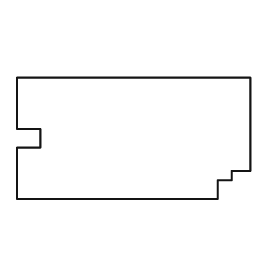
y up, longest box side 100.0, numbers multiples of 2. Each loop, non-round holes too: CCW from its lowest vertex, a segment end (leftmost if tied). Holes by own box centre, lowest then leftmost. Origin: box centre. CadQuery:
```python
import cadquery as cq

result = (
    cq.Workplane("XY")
    .moveTo(-50.0, -26.0)
    .lineTo(36.0, -26.0)
    .lineTo(36.0, -18.0)
    .lineTo(42.0, -18.0)
    .lineTo(42.0, -14.0)
    .lineTo(50.0, -14.0)
    .lineTo(50.0, 26.0)
    .lineTo(-50.0, 26.0)
    .lineTo(-50.0, 4.0)
    .lineTo(-40.0, 4.0)
    .lineTo(-40.0, -4.0)
    .lineTo(-50.0, -4.0)
    .close()
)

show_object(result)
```